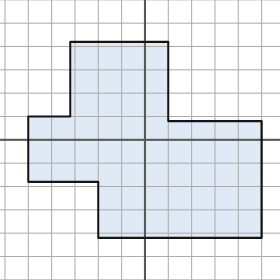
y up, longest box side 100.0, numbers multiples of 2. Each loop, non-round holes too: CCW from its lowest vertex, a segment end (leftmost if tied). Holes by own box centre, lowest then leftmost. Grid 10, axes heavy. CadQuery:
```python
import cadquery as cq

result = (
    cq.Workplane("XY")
    .moveTo(-20.0, -42.0)
    .lineTo(50.0, -42.0)
    .lineTo(50.0, 8.0)
    .lineTo(10.0, 8.0)
    .lineTo(10.0, 42.0)
    .lineTo(-32.0, 42.0)
    .lineTo(-32.0, 10.0)
    .lineTo(-50.0, 10.0)
    .lineTo(-50.0, -18.0)
    .lineTo(-20.0, -18.0)
    .close()
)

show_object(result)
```